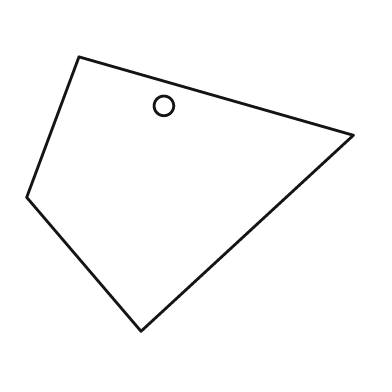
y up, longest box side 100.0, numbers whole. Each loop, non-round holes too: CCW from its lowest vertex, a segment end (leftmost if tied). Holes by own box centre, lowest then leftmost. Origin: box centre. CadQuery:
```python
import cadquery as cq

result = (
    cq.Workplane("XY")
    .moveTo(-15.0, -42.0)
    .lineTo(50.0, 18.0)
    .lineTo(-34.0, 42.0)
    .lineTo(-50.0, -1.0)
    .close()
    .moveTo(-8.0, 27.0)
    .circle(3.0)
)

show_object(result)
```